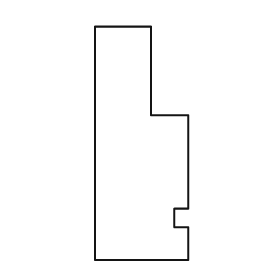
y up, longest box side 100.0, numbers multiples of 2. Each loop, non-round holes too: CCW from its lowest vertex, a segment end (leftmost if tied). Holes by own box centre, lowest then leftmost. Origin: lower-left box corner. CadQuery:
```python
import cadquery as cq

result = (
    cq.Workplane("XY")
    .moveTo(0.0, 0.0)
    .lineTo(40.0, 0.0)
    .lineTo(40.0, 14.0)
    .lineTo(34.0, 14.0)
    .lineTo(34.0, 22.0)
    .lineTo(40.0, 22.0)
    .lineTo(40.0, 62.0)
    .lineTo(24.0, 62.0)
    .lineTo(24.0, 100.0)
    .lineTo(0.0, 100.0)
    .close()
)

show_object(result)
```